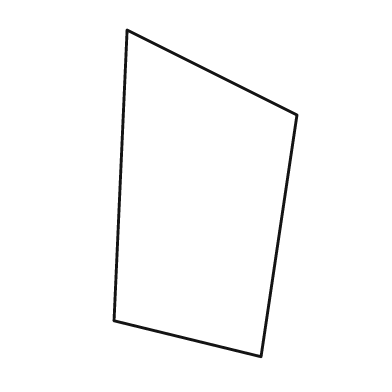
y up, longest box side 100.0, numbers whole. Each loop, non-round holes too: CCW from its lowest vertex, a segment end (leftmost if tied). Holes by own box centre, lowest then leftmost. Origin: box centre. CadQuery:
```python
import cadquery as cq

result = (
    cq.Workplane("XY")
    .moveTo(17.0, -50.0)
    .lineTo(28.0, 24.0)
    .lineTo(-24.0, 50.0)
    .lineTo(-28.0, -39.0)
    .close()
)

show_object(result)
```